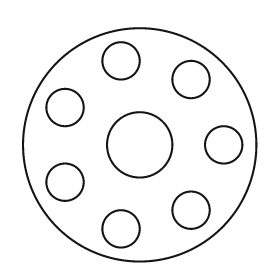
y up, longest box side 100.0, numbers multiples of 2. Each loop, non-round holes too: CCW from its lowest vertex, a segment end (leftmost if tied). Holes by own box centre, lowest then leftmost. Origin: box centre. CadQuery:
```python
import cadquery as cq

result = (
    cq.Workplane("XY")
    .moveTo(0.0, 0.0)
    .circle(50.0)
    .moveTo(-8.0, -36.0)
    .circle(8.0)
    .moveTo(22.0, -28.0)
    .circle(8.0)
    .moveTo(-32.0, -16.0)
    .circle(8.0)
    .moveTo(0.0, 0.0)
    .circle(14.0)
    .moveTo(36.0, 0.0)
    .circle(8.0)
    .moveTo(-32.0, 16.0)
    .circle(8.0)
    .moveTo(22.0, 28.0)
    .circle(8.0)
    .moveTo(-8.0, 36.0)
    .circle(8.0)
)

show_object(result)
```